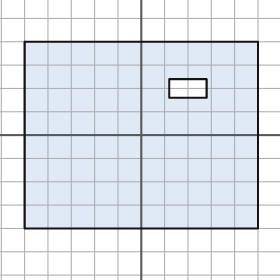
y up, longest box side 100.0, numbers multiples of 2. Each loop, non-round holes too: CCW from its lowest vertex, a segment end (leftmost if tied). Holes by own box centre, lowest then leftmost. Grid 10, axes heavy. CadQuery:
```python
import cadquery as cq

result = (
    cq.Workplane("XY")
    .moveTo(-50.0, -40.0)
    .lineTo(50.0, -40.0)
    .lineTo(50.0, 40.0)
    .lineTo(-50.0, 40.0)
    .close()
    .moveTo(12.0, 16.0)
    .lineTo(28.0, 16.0)
    .lineTo(28.0, 24.0)
    .lineTo(12.0, 24.0)
    .close()
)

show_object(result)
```